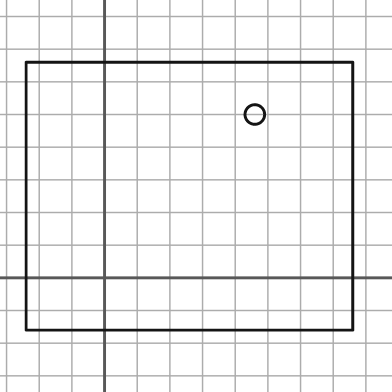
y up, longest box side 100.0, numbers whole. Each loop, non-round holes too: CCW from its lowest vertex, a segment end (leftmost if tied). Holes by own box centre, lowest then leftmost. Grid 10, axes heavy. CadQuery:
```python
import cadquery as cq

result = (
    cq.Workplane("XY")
    .moveTo(-24.0, -16.0)
    .lineTo(76.0, -16.0)
    .lineTo(76.0, 66.0)
    .lineTo(-24.0, 66.0)
    .close()
    .moveTo(46.0, 50.0)
    .circle(3.0)
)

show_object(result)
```